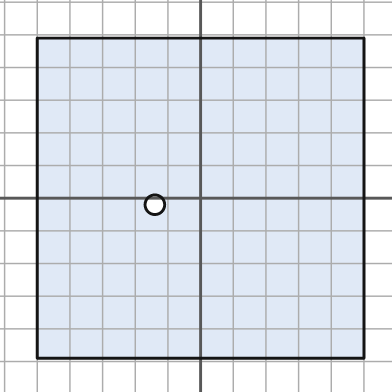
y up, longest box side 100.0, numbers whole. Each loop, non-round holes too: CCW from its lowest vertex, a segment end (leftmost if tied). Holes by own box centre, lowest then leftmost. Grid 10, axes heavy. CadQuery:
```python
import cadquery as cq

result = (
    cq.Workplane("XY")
    .moveTo(-50.0, -49.0)
    .lineTo(50.0, -49.0)
    .lineTo(50.0, 49.0)
    .lineTo(-50.0, 49.0)
    .close()
    .moveTo(-14.0, -2.0)
    .circle(3.0)
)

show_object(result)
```